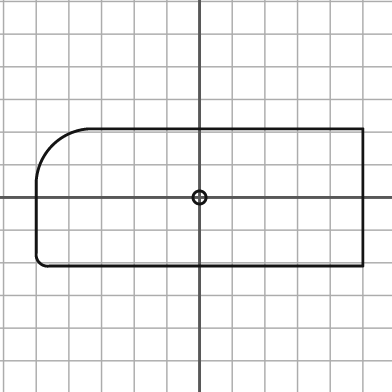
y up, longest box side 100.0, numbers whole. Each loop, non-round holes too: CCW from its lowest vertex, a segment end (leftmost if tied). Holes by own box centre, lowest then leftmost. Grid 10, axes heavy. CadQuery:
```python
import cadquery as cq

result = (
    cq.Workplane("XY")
    .moveTo(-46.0, -21.0)
    .lineTo(50.0, -21.0)
    .lineTo(50.0, 21.0)
    .lineTo(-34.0, 21.0)
    .threePointArc((-45.0, 16.0), (-50.0, 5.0))
    .lineTo(-50.0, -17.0)
    .threePointArc((-49.0, -20.0), (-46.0, -21.0))
    .close()
    .moveTo(0.0, 0.0)
    .circle(2.0)
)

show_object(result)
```